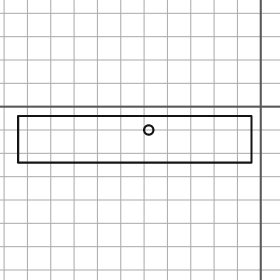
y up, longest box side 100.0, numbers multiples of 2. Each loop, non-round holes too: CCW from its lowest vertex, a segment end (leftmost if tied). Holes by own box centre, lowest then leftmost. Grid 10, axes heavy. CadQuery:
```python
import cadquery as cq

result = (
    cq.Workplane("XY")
    .moveTo(-104.0, -24.0)
    .lineTo(-4.0, -24.0)
    .lineTo(-4.0, -4.0)
    .lineTo(-104.0, -4.0)
    .close()
    .moveTo(-48.0, -10.0)
    .circle(2.0)
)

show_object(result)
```